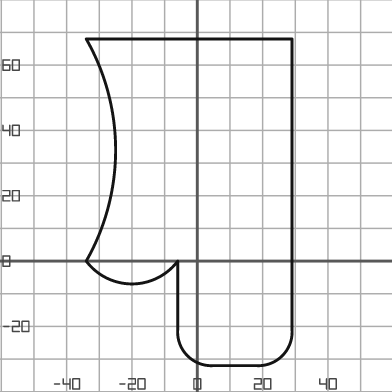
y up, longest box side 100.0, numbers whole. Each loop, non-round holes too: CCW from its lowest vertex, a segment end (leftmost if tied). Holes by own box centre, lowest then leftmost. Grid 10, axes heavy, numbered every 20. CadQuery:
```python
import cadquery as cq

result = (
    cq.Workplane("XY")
    .moveTo(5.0, -32.0)
    .lineTo(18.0, -32.0)
    .threePointArc((26.0, -29.0), (29.0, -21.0))
    .lineTo(29.0, 68.0)
    .lineTo(-34.0, 68.0)
    .threePointArc((-25.0, 34.0), (-34.0, 0.0))
    .threePointArc((-20.0, -7.0), (-6.0, 0.0))
    .lineTo(-6.0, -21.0)
    .threePointArc((-3.0, -29.0), (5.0, -32.0))
    .close()
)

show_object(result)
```